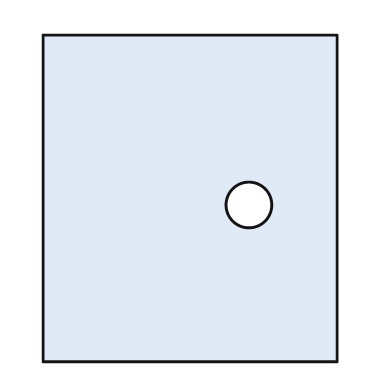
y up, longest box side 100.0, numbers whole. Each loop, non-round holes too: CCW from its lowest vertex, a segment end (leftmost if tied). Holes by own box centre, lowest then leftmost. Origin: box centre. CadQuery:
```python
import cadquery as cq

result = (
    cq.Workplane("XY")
    .moveTo(-45.0, -50.0)
    .lineTo(45.0, -50.0)
    .lineTo(45.0, 50.0)
    .lineTo(-45.0, 50.0)
    .close()
    .moveTo(18.0, -2.0)
    .circle(7.0)
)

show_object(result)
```